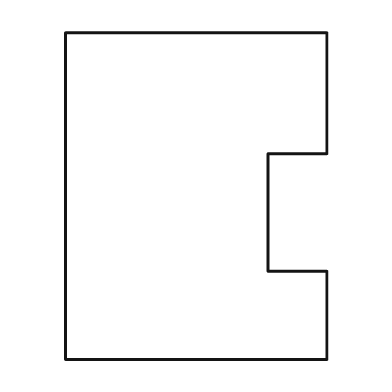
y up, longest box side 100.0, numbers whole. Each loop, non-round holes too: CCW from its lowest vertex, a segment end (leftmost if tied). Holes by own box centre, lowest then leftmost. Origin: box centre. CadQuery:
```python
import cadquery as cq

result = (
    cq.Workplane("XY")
    .moveTo(-40.0, -50.0)
    .lineTo(40.0, -50.0)
    .lineTo(40.0, -23.0)
    .lineTo(22.0, -23.0)
    .lineTo(22.0, 13.0)
    .lineTo(40.0, 13.0)
    .lineTo(40.0, 50.0)
    .lineTo(-40.0, 50.0)
    .close()
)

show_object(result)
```